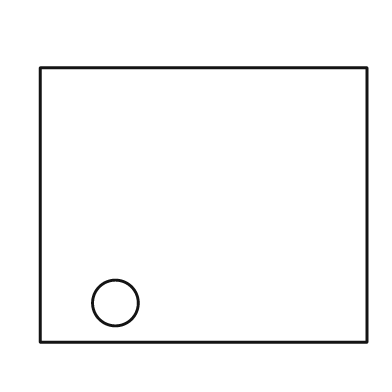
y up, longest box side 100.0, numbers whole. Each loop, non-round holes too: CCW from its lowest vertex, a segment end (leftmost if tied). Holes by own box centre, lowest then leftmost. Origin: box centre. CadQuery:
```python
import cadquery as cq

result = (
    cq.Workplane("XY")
    .moveTo(-50.0, -42.0)
    .lineTo(50.0, -42.0)
    .lineTo(50.0, 42.0)
    .lineTo(-50.0, 42.0)
    .close()
    .moveTo(-27.0, -30.0)
    .circle(7.0)
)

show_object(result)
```